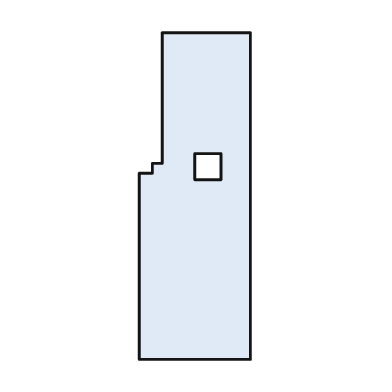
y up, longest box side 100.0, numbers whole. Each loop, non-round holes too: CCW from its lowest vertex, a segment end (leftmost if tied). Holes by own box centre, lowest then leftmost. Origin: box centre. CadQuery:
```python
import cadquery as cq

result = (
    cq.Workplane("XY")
    .moveTo(-17.0, -50.0)
    .lineTo(17.0, -50.0)
    .lineTo(17.0, 50.0)
    .lineTo(-10.0, 50.0)
    .lineTo(-10.0, 10.0)
    .lineTo(-13.0, 10.0)
    .lineTo(-13.0, 7.0)
    .lineTo(-17.0, 7.0)
    .close()
    .moveTo(0.0, 5.0)
    .lineTo(8.0, 5.0)
    .lineTo(8.0, 13.0)
    .lineTo(0.0, 13.0)
    .close()
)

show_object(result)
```